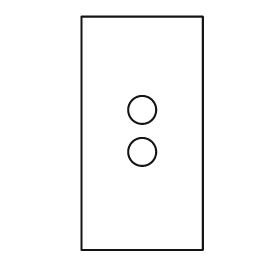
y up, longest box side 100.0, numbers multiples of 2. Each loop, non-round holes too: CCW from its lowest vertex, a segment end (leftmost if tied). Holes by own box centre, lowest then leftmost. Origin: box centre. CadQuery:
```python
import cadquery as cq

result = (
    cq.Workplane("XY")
    .moveTo(-26.0, -50.0)
    .lineTo(26.0, -50.0)
    .lineTo(26.0, 50.0)
    .lineTo(-26.0, 50.0)
    .close()
    .moveTo(0.0, -8.0)
    .circle(6.0)
    .moveTo(0.0, 10.0)
    .circle(6.0)
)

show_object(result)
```